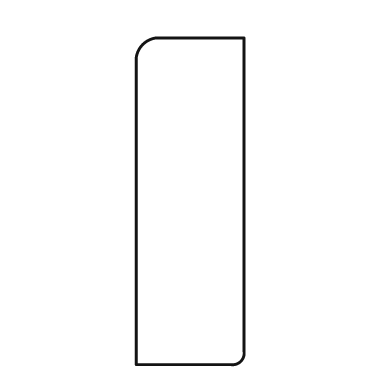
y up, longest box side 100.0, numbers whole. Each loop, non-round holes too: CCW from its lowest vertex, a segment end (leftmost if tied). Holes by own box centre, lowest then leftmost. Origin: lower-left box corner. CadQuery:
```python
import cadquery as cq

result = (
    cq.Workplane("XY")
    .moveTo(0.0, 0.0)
    .lineTo(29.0, 0.0)
    .threePointArc((32.0, 1.0), (33.0, 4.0))
    .lineTo(33.0, 100.0)
    .lineTo(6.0, 100.0)
    .threePointArc((2.0, 98.0), (0.0, 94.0))
    .close()
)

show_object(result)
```